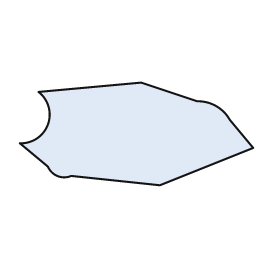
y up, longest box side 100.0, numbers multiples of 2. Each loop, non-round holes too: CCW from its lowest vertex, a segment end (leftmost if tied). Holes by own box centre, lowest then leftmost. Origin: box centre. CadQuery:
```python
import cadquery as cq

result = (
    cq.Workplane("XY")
    .moveTo(10.0, -22.0)
    .lineTo(50.0, -6.0)
    .lineTo(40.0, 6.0)
    .threePointArc((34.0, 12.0), (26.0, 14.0))
    .lineTo(2.0, 22.0)
    .lineTo(-42.0, 18.0)
    .threePointArc((-38.0, 4.0), (-50.0, -4.0))
    .lineTo(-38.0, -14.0)
    .threePointArc((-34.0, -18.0), (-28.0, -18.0))
    .close()
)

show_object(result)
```